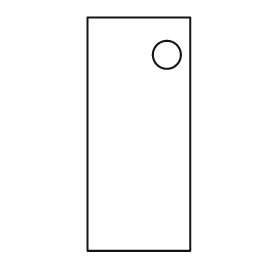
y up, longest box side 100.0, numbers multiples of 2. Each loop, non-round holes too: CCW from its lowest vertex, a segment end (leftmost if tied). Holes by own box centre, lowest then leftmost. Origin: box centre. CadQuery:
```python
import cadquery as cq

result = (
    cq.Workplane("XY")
    .moveTo(-22.0, -50.0)
    .lineTo(22.0, -50.0)
    .lineTo(22.0, 50.0)
    .lineTo(-22.0, 50.0)
    .close()
    .moveTo(12.0, 34.0)
    .circle(6.0)
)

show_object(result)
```